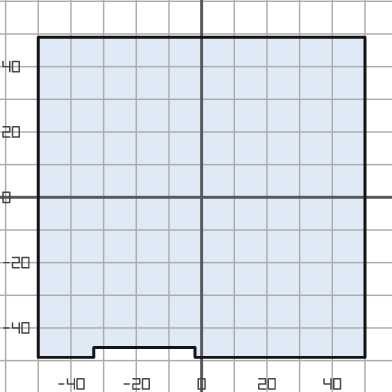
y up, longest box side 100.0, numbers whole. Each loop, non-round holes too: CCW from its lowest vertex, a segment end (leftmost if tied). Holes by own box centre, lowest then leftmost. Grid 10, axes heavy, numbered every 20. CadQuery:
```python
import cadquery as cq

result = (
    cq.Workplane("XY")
    .moveTo(-50.0, -49.0)
    .lineTo(-33.0, -49.0)
    .lineTo(-33.0, -46.0)
    .lineTo(-2.0, -46.0)
    .lineTo(-2.0, -49.0)
    .lineTo(50.0, -49.0)
    .lineTo(50.0, 49.0)
    .lineTo(-50.0, 49.0)
    .close()
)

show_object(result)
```